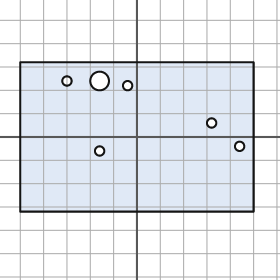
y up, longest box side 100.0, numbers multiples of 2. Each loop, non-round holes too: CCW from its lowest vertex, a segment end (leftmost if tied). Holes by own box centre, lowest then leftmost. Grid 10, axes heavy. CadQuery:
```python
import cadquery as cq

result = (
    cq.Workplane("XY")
    .moveTo(-50.0, -32.0)
    .lineTo(50.0, -32.0)
    .lineTo(50.0, 32.0)
    .lineTo(-50.0, 32.0)
    .close()
    .moveTo(-16.0, -6.0)
    .circle(2.0)
    .moveTo(44.0, -4.0)
    .circle(2.0)
    .moveTo(32.0, 6.0)
    .circle(2.0)
    .moveTo(-4.0, 22.0)
    .circle(2.0)
    .moveTo(-30.0, 24.0)
    .circle(2.0)
    .moveTo(-16.0, 24.0)
    .circle(4.0)
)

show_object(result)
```